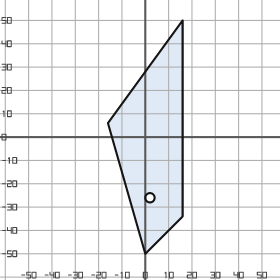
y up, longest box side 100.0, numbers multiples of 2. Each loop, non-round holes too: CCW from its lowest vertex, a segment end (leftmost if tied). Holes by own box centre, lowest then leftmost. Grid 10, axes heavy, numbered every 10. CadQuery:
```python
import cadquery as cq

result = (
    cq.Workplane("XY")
    .moveTo(0.0, -50.0)
    .lineTo(16.0, -34.0)
    .lineTo(16.0, 50.0)
    .lineTo(-16.0, 6.0)
    .close()
    .moveTo(2.0, -26.0)
    .circle(2.0)
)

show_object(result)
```